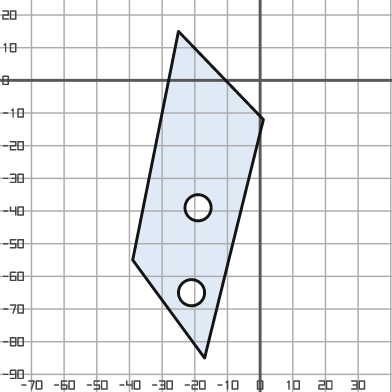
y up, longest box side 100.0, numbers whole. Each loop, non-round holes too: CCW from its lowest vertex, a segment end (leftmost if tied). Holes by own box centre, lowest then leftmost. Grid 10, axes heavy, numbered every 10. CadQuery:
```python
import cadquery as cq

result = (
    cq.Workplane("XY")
    .moveTo(-17.0, -85.0)
    .lineTo(1.0, -12.0)
    .lineTo(-25.0, 15.0)
    .lineTo(-39.0, -55.0)
    .close()
    .moveTo(-21.0, -65.0)
    .circle(4.0)
    .moveTo(-19.0, -39.0)
    .circle(4.0)
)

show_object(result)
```